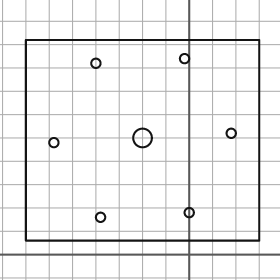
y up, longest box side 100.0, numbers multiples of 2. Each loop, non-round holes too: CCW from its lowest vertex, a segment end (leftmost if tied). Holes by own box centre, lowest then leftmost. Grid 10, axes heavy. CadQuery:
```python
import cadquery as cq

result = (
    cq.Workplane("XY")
    .moveTo(-70.0, 6.0)
    .lineTo(30.0, 6.0)
    .lineTo(30.0, 92.0)
    .lineTo(-70.0, 92.0)
    .close()
    .moveTo(-38.0, 16.0)
    .circle(2.0)
    .moveTo(0.0, 18.0)
    .circle(2.0)
    .moveTo(-58.0, 48.0)
    .circle(2.0)
    .moveTo(-20.0, 50.0)
    .circle(4.0)
    .moveTo(18.0, 52.0)
    .circle(2.0)
    .moveTo(-40.0, 82.0)
    .circle(2.0)
    .moveTo(-2.0, 84.0)
    .circle(2.0)
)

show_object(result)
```